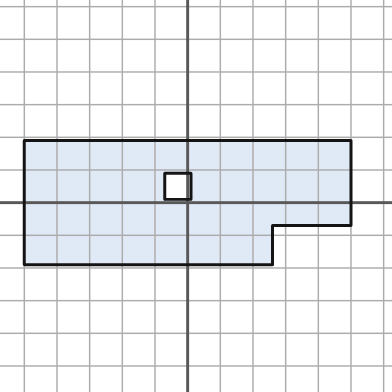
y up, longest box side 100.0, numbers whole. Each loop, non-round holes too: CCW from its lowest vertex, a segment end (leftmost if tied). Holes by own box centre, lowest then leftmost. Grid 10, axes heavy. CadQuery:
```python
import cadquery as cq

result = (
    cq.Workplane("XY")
    .moveTo(-50.0, -19.0)
    .lineTo(26.0, -19.0)
    .lineTo(26.0, -7.0)
    .lineTo(50.0, -7.0)
    .lineTo(50.0, 19.0)
    .lineTo(-50.0, 19.0)
    .close()
    .moveTo(-7.0, 1.0)
    .lineTo(1.0, 1.0)
    .lineTo(1.0, 9.0)
    .lineTo(-7.0, 9.0)
    .close()
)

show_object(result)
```